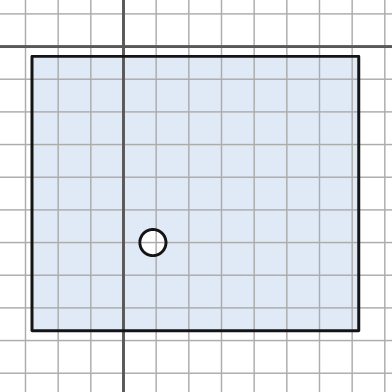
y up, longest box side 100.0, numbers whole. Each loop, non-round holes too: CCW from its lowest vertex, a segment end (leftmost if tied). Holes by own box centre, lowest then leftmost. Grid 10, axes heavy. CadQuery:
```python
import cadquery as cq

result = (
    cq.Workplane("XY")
    .moveTo(-28.0, -87.0)
    .lineTo(72.0, -87.0)
    .lineTo(72.0, -3.0)
    .lineTo(-28.0, -3.0)
    .close()
    .moveTo(9.0, -60.0)
    .circle(4.0)
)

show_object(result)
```